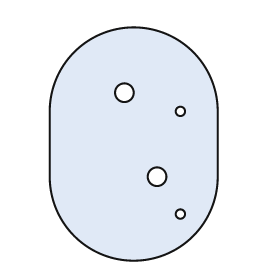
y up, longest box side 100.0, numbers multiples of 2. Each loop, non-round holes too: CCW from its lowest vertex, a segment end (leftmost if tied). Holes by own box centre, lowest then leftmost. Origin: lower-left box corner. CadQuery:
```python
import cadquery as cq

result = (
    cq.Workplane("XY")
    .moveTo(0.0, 36.0)
    .threePointArc((36.0, 0.0), (72.0, 36.0))
    .lineTo(72.0, 64.0)
    .threePointArc((36.0, 100.0), (0.0, 64.0))
    .close()
    .moveTo(56.0, 20.0)
    .circle(2.0)
    .moveTo(46.0, 36.0)
    .circle(4.0)
    .moveTo(56.0, 64.0)
    .circle(2.0)
    .moveTo(32.0, 72.0)
    .circle(4.0)
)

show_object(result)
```